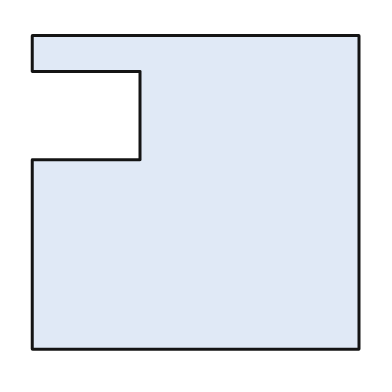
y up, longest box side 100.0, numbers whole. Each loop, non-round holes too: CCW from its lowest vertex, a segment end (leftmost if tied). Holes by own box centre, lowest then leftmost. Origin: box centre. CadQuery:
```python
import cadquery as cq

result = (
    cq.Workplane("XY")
    .moveTo(-50.0, -48.0)
    .lineTo(50.0, -48.0)
    .lineTo(50.0, 48.0)
    .lineTo(-50.0, 48.0)
    .lineTo(-50.0, 37.0)
    .lineTo(-17.0, 37.0)
    .lineTo(-17.0, 10.0)
    .lineTo(-50.0, 10.0)
    .close()
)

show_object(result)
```